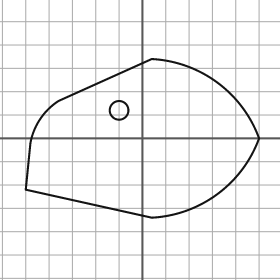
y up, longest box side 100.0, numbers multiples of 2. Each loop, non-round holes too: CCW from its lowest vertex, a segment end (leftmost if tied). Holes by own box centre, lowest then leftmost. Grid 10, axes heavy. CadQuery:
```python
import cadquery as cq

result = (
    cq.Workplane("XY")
    .moveTo(4.0, -34.0)
    .threePointArc((32.0, -24.0), (50.0, 0.0))
    .threePointArc((32.0, 24.0), (4.0, 34.0))
    .lineTo(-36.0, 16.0)
    .threePointArc((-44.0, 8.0), (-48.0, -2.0))
    .lineTo(-50.0, -22.0)
    .close()
    .moveTo(-10.0, 12.0)
    .circle(4.0)
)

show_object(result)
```